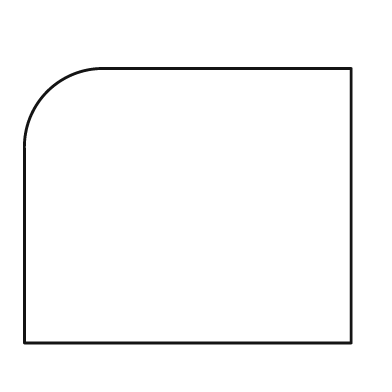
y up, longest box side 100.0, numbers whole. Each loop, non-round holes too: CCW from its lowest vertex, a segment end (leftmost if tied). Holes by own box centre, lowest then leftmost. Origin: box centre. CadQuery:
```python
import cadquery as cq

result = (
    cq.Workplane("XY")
    .moveTo(-50.0, -42.0)
    .lineTo(50.0, -42.0)
    .lineTo(50.0, 42.0)
    .lineTo(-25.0, 42.0)
    .threePointArc((-43.0, 35.0), (-50.0, 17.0))
    .close()
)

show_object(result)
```